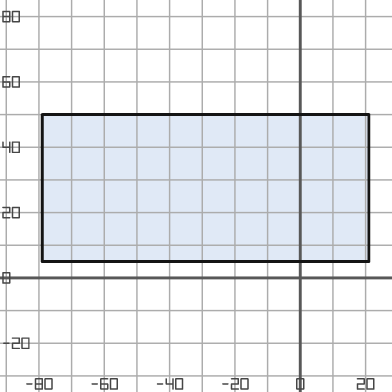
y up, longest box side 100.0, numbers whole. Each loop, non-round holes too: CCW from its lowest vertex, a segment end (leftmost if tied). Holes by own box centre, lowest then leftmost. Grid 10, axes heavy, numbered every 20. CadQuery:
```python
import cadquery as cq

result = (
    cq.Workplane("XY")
    .moveTo(-79.0, 5.0)
    .lineTo(21.0, 5.0)
    .lineTo(21.0, 50.0)
    .lineTo(-79.0, 50.0)
    .close()
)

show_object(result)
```